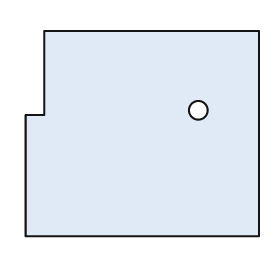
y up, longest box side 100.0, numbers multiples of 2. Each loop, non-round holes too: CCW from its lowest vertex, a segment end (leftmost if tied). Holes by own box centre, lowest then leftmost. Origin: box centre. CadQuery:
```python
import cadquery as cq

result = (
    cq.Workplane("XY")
    .moveTo(-50.0, -44.0)
    .lineTo(50.0, -44.0)
    .lineTo(50.0, 44.0)
    .lineTo(-42.0, 44.0)
    .lineTo(-42.0, 8.0)
    .lineTo(-50.0, 8.0)
    .close()
    .moveTo(24.0, 10.0)
    .circle(4.0)
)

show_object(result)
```